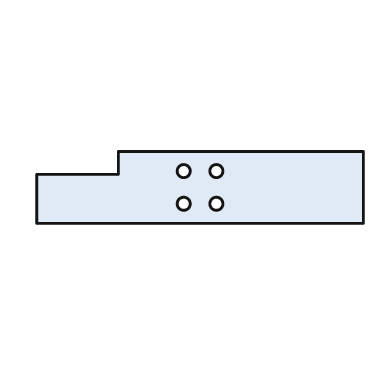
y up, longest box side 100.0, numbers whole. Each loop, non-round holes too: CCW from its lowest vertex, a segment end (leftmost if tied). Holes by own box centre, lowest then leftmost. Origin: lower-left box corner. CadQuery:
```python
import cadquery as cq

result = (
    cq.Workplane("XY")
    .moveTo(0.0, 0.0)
    .lineTo(100.0, 0.0)
    .lineTo(100.0, 22.0)
    .lineTo(25.0, 22.0)
    .lineTo(25.0, 15.0)
    .lineTo(0.0, 15.0)
    .close()
    .moveTo(45.0, 6.0)
    .circle(2.0)
    .moveTo(55.0, 6.0)
    .circle(2.0)
    .moveTo(45.0, 16.0)
    .circle(2.0)
    .moveTo(55.0, 16.0)
    .circle(2.0)
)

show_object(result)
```